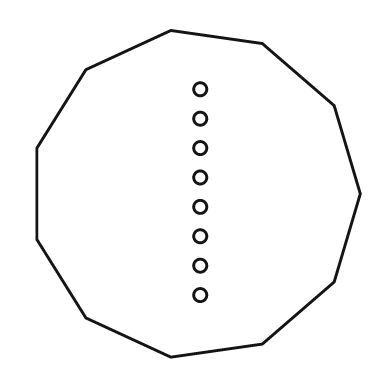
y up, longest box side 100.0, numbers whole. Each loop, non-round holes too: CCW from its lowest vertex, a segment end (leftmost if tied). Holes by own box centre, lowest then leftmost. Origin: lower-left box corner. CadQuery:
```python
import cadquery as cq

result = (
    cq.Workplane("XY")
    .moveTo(41.0, 0.0)
    .lineTo(69.0, 4.0)
    .lineTo(91.0, 23.0)
    .lineTo(99.0, 50.0)
    .lineTo(91.0, 77.0)
    .lineTo(69.0, 96.0)
    .lineTo(41.0, 100.0)
    .lineTo(15.0, 88.0)
    .lineTo(0.0, 64.0)
    .lineTo(0.0, 36.0)
    .lineTo(15.0, 12.0)
    .close()
    .moveTo(50.0, 19.0)
    .circle(2.0)
    .moveTo(50.0, 28.0)
    .circle(2.0)
    .moveTo(50.0, 37.0)
    .circle(2.0)
    .moveTo(50.0, 46.0)
    .circle(2.0)
    .moveTo(50.0, 55.0)
    .circle(2.0)
    .moveTo(50.0, 64.0)
    .circle(2.0)
    .moveTo(50.0, 73.0)
    .circle(2.0)
    .moveTo(50.0, 82.0)
    .circle(2.0)
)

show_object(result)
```